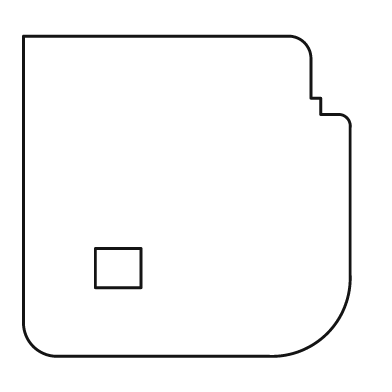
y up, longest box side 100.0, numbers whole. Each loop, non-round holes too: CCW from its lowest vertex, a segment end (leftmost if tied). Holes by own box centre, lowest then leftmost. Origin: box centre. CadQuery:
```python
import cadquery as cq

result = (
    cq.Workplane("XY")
    .moveTo(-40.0, -49.0)
    .lineTo(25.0, -49.0)
    .threePointArc((43.0, -42.0), (50.0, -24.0))
    .lineTo(50.0, 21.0)
    .threePointArc((49.0, 24.0), (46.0, 25.0))
    .lineTo(41.0, 25.0)
    .lineTo(41.0, 30.0)
    .lineTo(38.0, 30.0)
    .lineTo(38.0, 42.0)
    .threePointArc((36.0, 47.0), (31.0, 49.0))
    .lineTo(-50.0, 49.0)
    .lineTo(-50.0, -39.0)
    .threePointArc((-47.0, -46.0), (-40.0, -49.0))
    .close()
    .moveTo(-28.0, -28.0)
    .lineTo(-14.0, -28.0)
    .lineTo(-14.0, -16.0)
    .lineTo(-28.0, -16.0)
    .close()
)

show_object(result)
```